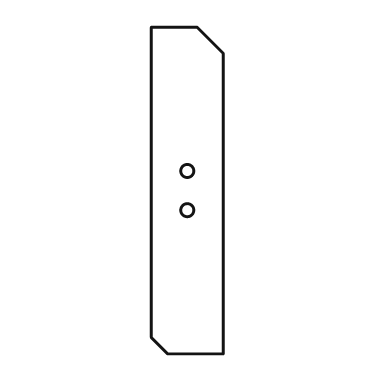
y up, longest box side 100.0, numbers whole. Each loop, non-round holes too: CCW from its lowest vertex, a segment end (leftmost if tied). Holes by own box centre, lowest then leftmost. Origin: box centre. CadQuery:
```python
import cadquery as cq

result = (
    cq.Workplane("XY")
    .moveTo(-6.0, -50.0)
    .lineTo(11.0, -50.0)
    .lineTo(11.0, 42.0)
    .lineTo(3.0, 50.0)
    .lineTo(-11.0, 50.0)
    .lineTo(-11.0, -45.0)
    .close()
    .moveTo(0.0, -6.0)
    .circle(2.0)
    .moveTo(0.0, 6.0)
    .circle(2.0)
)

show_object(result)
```